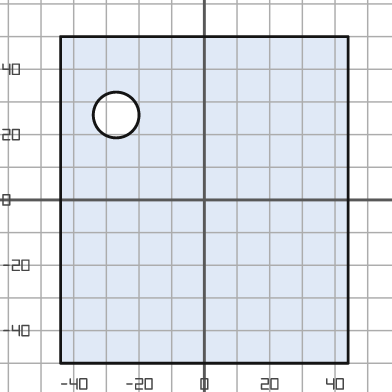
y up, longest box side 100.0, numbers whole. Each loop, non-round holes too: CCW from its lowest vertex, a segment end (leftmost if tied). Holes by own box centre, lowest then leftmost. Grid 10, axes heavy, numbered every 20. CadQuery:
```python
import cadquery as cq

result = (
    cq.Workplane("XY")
    .moveTo(-44.0, -50.0)
    .lineTo(44.0, -50.0)
    .lineTo(44.0, 50.0)
    .lineTo(-44.0, 50.0)
    .close()
    .moveTo(-27.0, 26.0)
    .circle(7.0)
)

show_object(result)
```